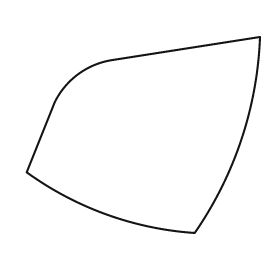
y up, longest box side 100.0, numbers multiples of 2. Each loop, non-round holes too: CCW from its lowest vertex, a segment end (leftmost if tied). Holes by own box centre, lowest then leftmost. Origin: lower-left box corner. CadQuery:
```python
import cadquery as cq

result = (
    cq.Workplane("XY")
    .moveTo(72.0, 0.0)
    .threePointArc((92.0, 40.0), (100.0, 84.0))
    .lineTo(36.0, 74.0)
    .threePointArc((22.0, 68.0), (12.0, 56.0))
    .lineTo(0.0, 26.0)
    .threePointArc((34.0, 8.0), (72.0, 0.0))
    .close()
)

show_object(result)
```